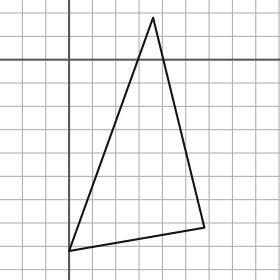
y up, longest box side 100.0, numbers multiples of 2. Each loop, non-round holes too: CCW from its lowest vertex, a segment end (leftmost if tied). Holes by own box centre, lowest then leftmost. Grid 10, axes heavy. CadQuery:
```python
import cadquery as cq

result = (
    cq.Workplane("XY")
    .moveTo(0.0, -82.0)
    .lineTo(58.0, -72.0)
    .lineTo(36.0, 18.0)
    .close()
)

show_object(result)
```